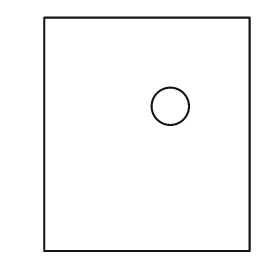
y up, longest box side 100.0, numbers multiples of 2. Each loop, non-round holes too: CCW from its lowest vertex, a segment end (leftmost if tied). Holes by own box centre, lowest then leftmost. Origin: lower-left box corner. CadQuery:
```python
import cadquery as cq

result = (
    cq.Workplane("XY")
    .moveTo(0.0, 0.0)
    .lineTo(88.0, 0.0)
    .lineTo(88.0, 100.0)
    .lineTo(0.0, 100.0)
    .close()
    .moveTo(54.0, 62.0)
    .circle(8.0)
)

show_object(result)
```